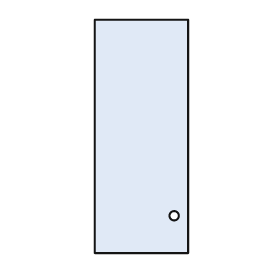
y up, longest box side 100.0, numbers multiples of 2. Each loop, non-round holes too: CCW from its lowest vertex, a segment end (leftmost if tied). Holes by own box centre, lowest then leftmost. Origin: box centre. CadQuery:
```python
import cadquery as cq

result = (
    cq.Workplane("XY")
    .moveTo(-20.0, -50.0)
    .lineTo(20.0, -50.0)
    .lineTo(20.0, 50.0)
    .lineTo(-20.0, 50.0)
    .close()
    .moveTo(14.0, -34.0)
    .circle(2.0)
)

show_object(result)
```